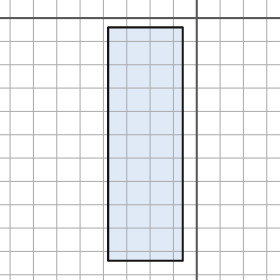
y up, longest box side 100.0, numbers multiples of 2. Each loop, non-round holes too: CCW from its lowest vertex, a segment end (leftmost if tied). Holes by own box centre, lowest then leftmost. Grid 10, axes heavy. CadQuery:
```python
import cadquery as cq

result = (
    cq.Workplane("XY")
    .moveTo(-38.0, -104.0)
    .lineTo(-6.0, -104.0)
    .lineTo(-6.0, -4.0)
    .lineTo(-38.0, -4.0)
    .close()
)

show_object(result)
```